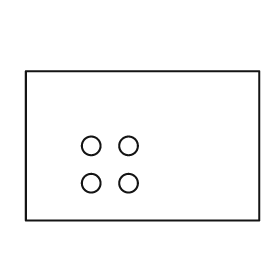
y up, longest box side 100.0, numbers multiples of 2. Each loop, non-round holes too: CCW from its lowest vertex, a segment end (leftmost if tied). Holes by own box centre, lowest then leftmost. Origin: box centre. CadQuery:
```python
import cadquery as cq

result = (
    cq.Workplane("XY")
    .moveTo(-50.0, -32.0)
    .lineTo(50.0, -32.0)
    .lineTo(50.0, 32.0)
    .lineTo(-50.0, 32.0)
    .close()
    .moveTo(-22.0, -16.0)
    .circle(4.0)
    .moveTo(-6.0, -16.0)
    .circle(4.0)
    .moveTo(-22.0, 0.0)
    .circle(4.0)
    .moveTo(-6.0, 0.0)
    .circle(4.0)
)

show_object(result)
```